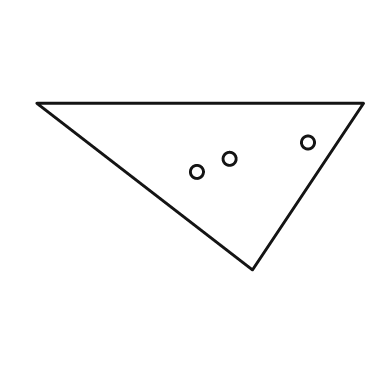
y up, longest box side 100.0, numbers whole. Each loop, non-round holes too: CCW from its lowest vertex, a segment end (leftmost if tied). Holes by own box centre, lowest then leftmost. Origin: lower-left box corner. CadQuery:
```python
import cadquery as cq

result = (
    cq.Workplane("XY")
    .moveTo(66.0, 0.0)
    .lineTo(100.0, 51.0)
    .lineTo(0.0, 51.0)
    .close()
    .moveTo(49.0, 30.0)
    .circle(2.0)
    .moveTo(59.0, 34.0)
    .circle(2.0)
    .moveTo(83.0, 39.0)
    .circle(2.0)
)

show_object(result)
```